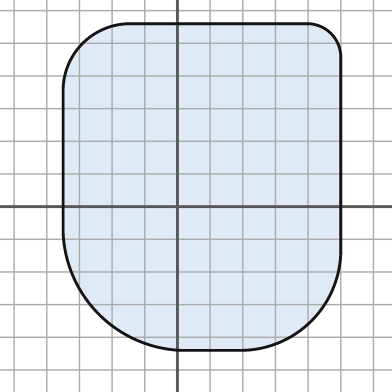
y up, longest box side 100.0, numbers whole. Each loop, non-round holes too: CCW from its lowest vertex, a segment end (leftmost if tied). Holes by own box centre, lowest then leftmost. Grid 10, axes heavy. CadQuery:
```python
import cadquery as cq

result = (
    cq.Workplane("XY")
    .moveTo(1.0, -44.0)
    .lineTo(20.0, -44.0)
    .threePointArc((41.0, -35.0), (50.0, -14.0))
    .lineTo(50.0, 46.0)
    .threePointArc((47.0, 53.0), (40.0, 56.0))
    .lineTo(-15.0, 56.0)
    .threePointArc((-29.0, 50.0), (-35.0, 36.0))
    .lineTo(-35.0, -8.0)
    .threePointArc((-24.0, -33.0), (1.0, -44.0))
    .close()
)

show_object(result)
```